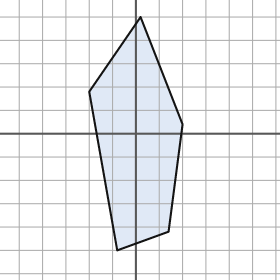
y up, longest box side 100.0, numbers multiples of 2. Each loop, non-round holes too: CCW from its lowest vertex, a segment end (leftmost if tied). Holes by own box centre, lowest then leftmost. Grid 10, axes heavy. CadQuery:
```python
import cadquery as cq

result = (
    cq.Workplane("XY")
    .moveTo(-8.0, -50.0)
    .lineTo(14.0, -42.0)
    .lineTo(20.0, 4.0)
    .lineTo(2.0, 50.0)
    .lineTo(-20.0, 18.0)
    .close()
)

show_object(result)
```